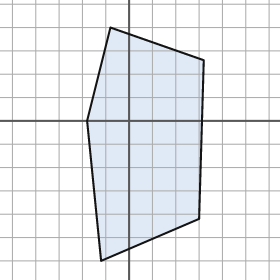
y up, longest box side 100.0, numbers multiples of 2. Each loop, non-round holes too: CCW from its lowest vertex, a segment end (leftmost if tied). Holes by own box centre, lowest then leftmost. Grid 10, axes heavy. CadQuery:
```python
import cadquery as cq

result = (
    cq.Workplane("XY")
    .moveTo(-12.0, -60.0)
    .lineTo(30.0, -42.0)
    .lineTo(32.0, 26.0)
    .lineTo(-8.0, 40.0)
    .lineTo(-18.0, 0.0)
    .close()
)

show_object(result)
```